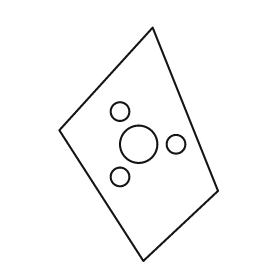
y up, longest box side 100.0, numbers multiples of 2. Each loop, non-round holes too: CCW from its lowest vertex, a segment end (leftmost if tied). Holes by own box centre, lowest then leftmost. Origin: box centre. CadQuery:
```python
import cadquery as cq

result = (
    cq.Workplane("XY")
    .moveTo(2.0, -50.0)
    .lineTo(34.0, -20.0)
    .lineTo(6.0, 50.0)
    .lineTo(-34.0, 6.0)
    .close()
    .moveTo(-8.0, -14.0)
    .circle(4.0)
    .moveTo(0.0, 0.0)
    .circle(8.0)
    .moveTo(16.0, 0.0)
    .circle(4.0)
    .moveTo(-8.0, 14.0)
    .circle(4.0)
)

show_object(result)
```